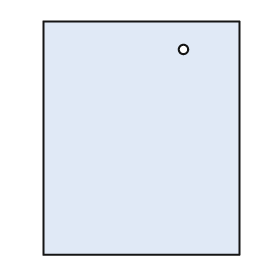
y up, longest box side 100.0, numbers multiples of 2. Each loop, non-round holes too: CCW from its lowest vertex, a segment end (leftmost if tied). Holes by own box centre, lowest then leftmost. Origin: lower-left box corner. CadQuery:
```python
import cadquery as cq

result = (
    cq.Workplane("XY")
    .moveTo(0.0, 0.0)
    .lineTo(84.0, 0.0)
    .lineTo(84.0, 100.0)
    .lineTo(0.0, 100.0)
    .close()
    .moveTo(60.0, 88.0)
    .circle(2.0)
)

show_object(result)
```